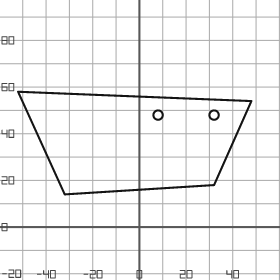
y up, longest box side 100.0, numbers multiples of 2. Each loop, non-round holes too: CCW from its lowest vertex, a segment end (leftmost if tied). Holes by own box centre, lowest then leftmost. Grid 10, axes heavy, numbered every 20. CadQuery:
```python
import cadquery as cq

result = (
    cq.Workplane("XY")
    .moveTo(-32.0, 14.0)
    .lineTo(32.0, 18.0)
    .lineTo(48.0, 54.0)
    .lineTo(-52.0, 58.0)
    .close()
    .moveTo(8.0, 48.0)
    .circle(2.0)
    .moveTo(32.0, 48.0)
    .circle(2.0)
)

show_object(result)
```